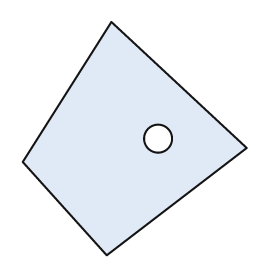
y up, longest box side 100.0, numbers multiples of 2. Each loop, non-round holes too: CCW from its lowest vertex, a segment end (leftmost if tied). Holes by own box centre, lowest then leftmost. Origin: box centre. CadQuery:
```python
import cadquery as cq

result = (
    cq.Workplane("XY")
    .moveTo(-12.0, -50.0)
    .lineTo(48.0, -4.0)
    .lineTo(-10.0, 50.0)
    .lineTo(-48.0, -10.0)
    .close()
    .moveTo(10.0, 0.0)
    .circle(6.0)
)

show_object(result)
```